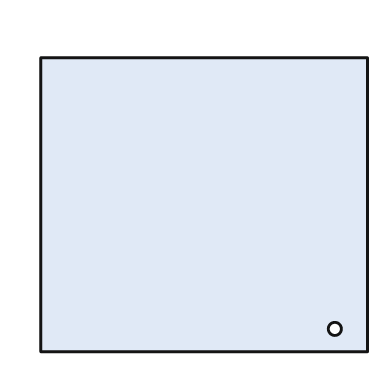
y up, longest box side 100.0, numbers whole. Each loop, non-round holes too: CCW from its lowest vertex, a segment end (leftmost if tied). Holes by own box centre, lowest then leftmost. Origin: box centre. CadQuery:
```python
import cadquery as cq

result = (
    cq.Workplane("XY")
    .moveTo(-50.0, -45.0)
    .lineTo(50.0, -45.0)
    .lineTo(50.0, 45.0)
    .lineTo(-50.0, 45.0)
    .close()
    .moveTo(40.0, -38.0)
    .circle(2.0)
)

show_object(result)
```